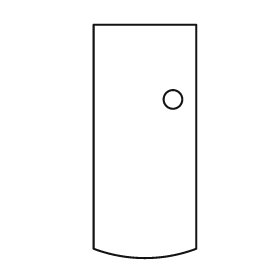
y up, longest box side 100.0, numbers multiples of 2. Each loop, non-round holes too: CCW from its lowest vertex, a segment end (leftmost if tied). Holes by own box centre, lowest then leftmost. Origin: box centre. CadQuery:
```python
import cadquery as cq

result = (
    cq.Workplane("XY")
    .moveTo(-22.0, -46.0)
    .threePointArc((0.0, -50.0), (22.0, -46.0))
    .lineTo(22.0, 50.0)
    .lineTo(-22.0, 50.0)
    .close()
    .moveTo(12.0, 18.0)
    .circle(4.0)
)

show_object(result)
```